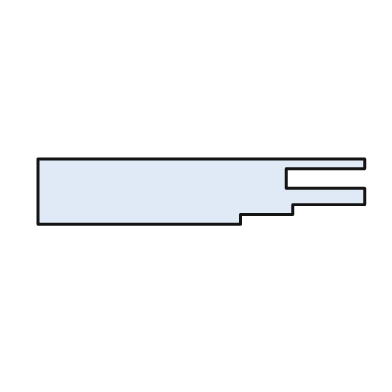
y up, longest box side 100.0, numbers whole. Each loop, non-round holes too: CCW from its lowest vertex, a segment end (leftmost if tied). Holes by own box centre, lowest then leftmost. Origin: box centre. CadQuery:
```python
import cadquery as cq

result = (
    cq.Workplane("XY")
    .moveTo(-50.0, -10.0)
    .lineTo(12.0, -10.0)
    .lineTo(12.0, -7.0)
    .lineTo(28.0, -7.0)
    .lineTo(28.0, -4.0)
    .lineTo(50.0, -4.0)
    .lineTo(50.0, 1.0)
    .lineTo(26.0, 1.0)
    .lineTo(26.0, 7.0)
    .lineTo(50.0, 7.0)
    .lineTo(50.0, 10.0)
    .lineTo(-50.0, 10.0)
    .close()
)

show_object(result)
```